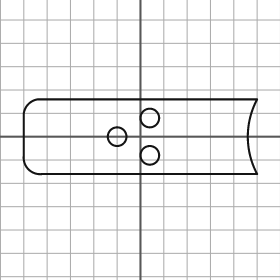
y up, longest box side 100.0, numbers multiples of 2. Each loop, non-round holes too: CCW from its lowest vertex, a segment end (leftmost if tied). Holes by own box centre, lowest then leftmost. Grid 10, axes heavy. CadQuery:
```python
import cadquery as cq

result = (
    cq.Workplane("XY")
    .moveTo(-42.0, -16.0)
    .lineTo(50.0, -16.0)
    .threePointArc((46.0, 0.0), (50.0, 16.0))
    .lineTo(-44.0, 16.0)
    .threePointArc((-48.0, 14.0), (-50.0, 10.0))
    .lineTo(-50.0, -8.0)
    .threePointArc((-48.0, -14.0), (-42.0, -16.0))
    .close()
    .moveTo(4.0, -8.0)
    .circle(4.0)
    .moveTo(-10.0, 0.0)
    .circle(4.0)
    .moveTo(4.0, 8.0)
    .circle(4.0)
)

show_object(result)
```